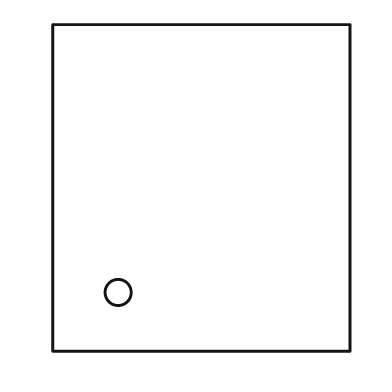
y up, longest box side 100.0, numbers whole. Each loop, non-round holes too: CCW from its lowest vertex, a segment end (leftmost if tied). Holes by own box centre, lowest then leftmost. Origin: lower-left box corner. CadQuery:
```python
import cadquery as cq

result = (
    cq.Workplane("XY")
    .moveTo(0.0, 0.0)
    .lineTo(91.0, 0.0)
    .lineTo(91.0, 100.0)
    .lineTo(0.0, 100.0)
    .close()
    .moveTo(20.0, 18.0)
    .circle(4.0)
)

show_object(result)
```